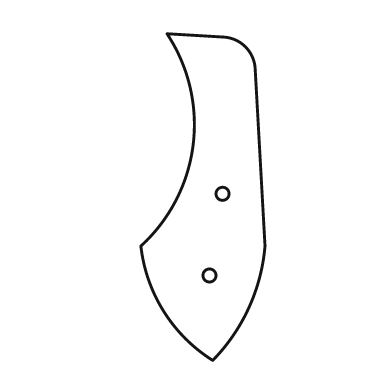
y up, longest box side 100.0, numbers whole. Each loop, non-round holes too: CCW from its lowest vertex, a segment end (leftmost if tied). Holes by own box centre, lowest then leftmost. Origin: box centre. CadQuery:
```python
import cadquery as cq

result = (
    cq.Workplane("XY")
    .moveTo(3.0, -50.0)
    .threePointArc((14.0, -34.0), (19.0, -15.0))
    .lineTo(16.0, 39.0)
    .threePointArc((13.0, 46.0), (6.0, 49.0))
    .lineTo(-11.0, 50.0)
    .threePointArc((-3.0, 16.0), (-19.0, -15.0))
    .threePointArc((-12.0, -35.0), (3.0, -50.0))
    .close()
    .moveTo(2.0, -24.0)
    .circle(2.0)
    .moveTo(6.0, 1.0)
    .circle(2.0)
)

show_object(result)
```